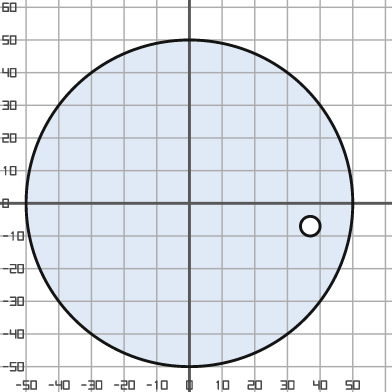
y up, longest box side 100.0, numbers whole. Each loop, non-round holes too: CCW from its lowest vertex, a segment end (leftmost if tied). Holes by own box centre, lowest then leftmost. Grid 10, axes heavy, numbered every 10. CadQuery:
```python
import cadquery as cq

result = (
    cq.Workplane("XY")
    .moveTo(0.0, 0.0)
    .circle(50.0)
    .moveTo(37.0, -7.0)
    .circle(3.0)
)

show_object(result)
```